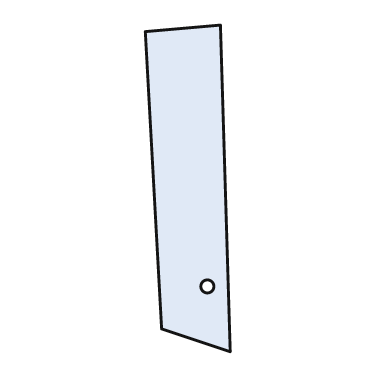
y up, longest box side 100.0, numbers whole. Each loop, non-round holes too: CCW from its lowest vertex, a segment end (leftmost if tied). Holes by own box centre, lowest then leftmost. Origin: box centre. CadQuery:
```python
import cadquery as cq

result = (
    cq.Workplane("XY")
    .moveTo(13.0, -50.0)
    .lineTo(10.0, 50.0)
    .lineTo(-13.0, 48.0)
    .lineTo(-8.0, -43.0)
    .close()
    .moveTo(6.0, -30.0)
    .circle(2.0)
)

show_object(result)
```